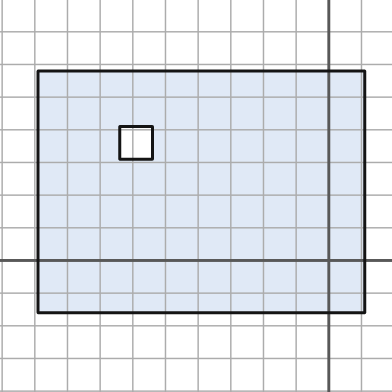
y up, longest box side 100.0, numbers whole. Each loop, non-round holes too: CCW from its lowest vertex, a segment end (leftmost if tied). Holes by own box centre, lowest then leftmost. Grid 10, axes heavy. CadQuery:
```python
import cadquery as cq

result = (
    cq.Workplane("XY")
    .moveTo(-89.0, -16.0)
    .lineTo(11.0, -16.0)
    .lineTo(11.0, 58.0)
    .lineTo(-89.0, 58.0)
    .close()
    .moveTo(-64.0, 31.0)
    .lineTo(-54.0, 31.0)
    .lineTo(-54.0, 41.0)
    .lineTo(-64.0, 41.0)
    .close()
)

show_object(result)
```